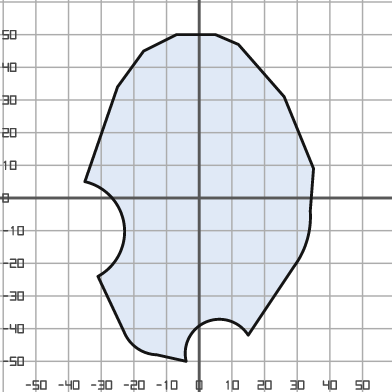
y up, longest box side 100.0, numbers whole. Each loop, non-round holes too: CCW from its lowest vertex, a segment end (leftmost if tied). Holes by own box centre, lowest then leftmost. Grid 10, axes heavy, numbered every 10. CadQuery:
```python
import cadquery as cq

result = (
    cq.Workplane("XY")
    .moveTo(-4.0, -50.0)
    .threePointArc((2.0, -38.0), (15.0, -42.0))
    .lineTo(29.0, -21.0)
    .threePointArc((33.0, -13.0), (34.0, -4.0))
    .lineTo(35.0, 9.0)
    .lineTo(26.0, 31.0)
    .lineTo(12.0, 47.0)
    .lineTo(5.0, 50.0)
    .lineTo(-7.0, 50.0)
    .lineTo(-17.0, 45.0)
    .lineTo(-25.0, 34.0)
    .lineTo(-35.0, 5.0)
    .threePointArc((-23.0, -8.0), (-31.0, -24.0))
    .lineTo(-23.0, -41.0)
    .threePointArc((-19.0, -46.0), (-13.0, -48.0))
    .close()
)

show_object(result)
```